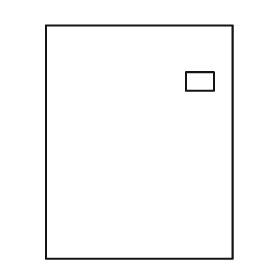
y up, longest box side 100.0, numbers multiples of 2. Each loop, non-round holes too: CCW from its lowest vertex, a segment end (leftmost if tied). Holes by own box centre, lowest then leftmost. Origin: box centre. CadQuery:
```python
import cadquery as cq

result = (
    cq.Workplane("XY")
    .moveTo(-40.0, -50.0)
    .lineTo(40.0, -50.0)
    .lineTo(40.0, 50.0)
    .lineTo(-40.0, 50.0)
    .close()
    .moveTo(20.0, 22.0)
    .lineTo(32.0, 22.0)
    .lineTo(32.0, 30.0)
    .lineTo(20.0, 30.0)
    .close()
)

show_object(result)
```